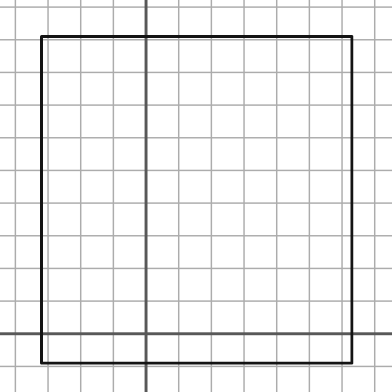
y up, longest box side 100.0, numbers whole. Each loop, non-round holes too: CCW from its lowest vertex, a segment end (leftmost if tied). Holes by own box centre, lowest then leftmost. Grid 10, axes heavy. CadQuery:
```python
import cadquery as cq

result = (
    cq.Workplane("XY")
    .moveTo(-32.0, -9.0)
    .lineTo(63.0, -9.0)
    .lineTo(63.0, 91.0)
    .lineTo(-32.0, 91.0)
    .close()
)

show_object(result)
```